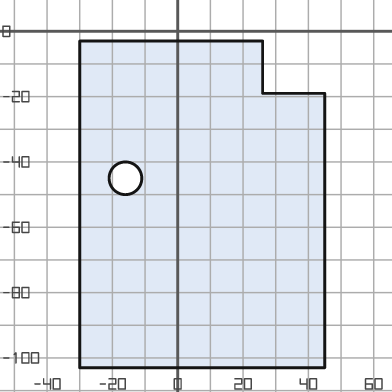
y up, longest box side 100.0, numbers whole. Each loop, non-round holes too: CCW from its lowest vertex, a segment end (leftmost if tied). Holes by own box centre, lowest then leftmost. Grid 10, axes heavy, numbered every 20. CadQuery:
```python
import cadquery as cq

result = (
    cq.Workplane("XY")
    .moveTo(-30.0, -103.0)
    .lineTo(45.0, -103.0)
    .lineTo(45.0, -19.0)
    .lineTo(26.0, -19.0)
    .lineTo(26.0, -3.0)
    .lineTo(-30.0, -3.0)
    .close()
    .moveTo(-16.0, -45.0)
    .circle(5.0)
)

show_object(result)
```